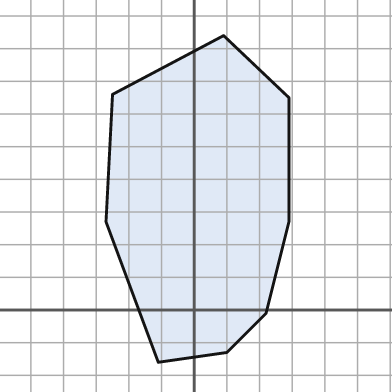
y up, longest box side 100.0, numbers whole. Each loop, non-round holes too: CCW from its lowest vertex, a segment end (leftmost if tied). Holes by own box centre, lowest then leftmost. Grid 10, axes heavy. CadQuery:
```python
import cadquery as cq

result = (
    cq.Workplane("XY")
    .moveTo(-11.0, -16.0)
    .lineTo(10.0, -13.0)
    .lineTo(22.0, -1.0)
    .lineTo(29.0, 27.0)
    .lineTo(29.0, 65.0)
    .lineTo(9.0, 84.0)
    .lineTo(-25.0, 66.0)
    .lineTo(-27.0, 27.0)
    .close()
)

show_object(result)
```